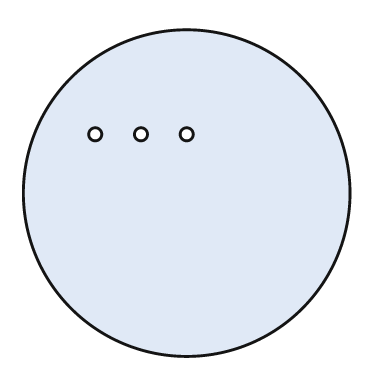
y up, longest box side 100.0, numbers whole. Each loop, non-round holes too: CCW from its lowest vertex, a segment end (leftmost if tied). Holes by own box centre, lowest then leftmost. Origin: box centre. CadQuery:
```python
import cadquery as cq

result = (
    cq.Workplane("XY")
    .moveTo(0.0, 0.0)
    .circle(50.0)
    .moveTo(-28.0, 18.0)
    .circle(2.0)
    .moveTo(-14.0, 18.0)
    .circle(2.0)
    .moveTo(0.0, 18.0)
    .circle(2.0)
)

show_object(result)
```